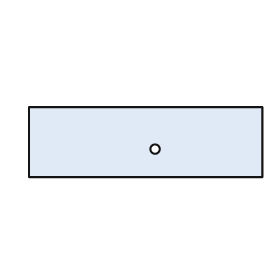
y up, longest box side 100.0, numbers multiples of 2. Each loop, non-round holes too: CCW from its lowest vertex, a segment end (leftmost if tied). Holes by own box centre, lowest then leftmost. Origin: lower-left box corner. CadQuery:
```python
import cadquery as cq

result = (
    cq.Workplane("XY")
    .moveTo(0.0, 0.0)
    .lineTo(100.0, 0.0)
    .lineTo(100.0, 30.0)
    .lineTo(0.0, 30.0)
    .close()
    .moveTo(54.0, 12.0)
    .circle(2.0)
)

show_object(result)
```